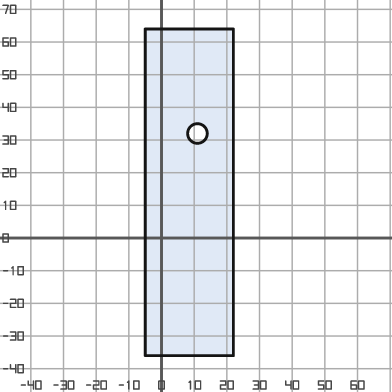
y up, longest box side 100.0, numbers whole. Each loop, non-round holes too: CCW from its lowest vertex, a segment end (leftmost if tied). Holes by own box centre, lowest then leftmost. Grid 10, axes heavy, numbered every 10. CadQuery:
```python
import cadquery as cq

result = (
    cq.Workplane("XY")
    .moveTo(-5.0, -36.0)
    .lineTo(22.0, -36.0)
    .lineTo(22.0, 64.0)
    .lineTo(-5.0, 64.0)
    .close()
    .moveTo(11.0, 32.0)
    .circle(3.0)
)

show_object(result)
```